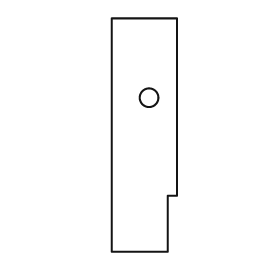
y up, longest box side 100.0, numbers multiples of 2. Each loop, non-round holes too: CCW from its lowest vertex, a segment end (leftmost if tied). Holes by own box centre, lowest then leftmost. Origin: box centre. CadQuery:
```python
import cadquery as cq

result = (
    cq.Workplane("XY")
    .moveTo(-14.0, -50.0)
    .lineTo(10.0, -50.0)
    .lineTo(10.0, -26.0)
    .lineTo(14.0, -26.0)
    .lineTo(14.0, 50.0)
    .lineTo(-14.0, 50.0)
    .close()
    .moveTo(2.0, 16.0)
    .circle(4.0)
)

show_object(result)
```